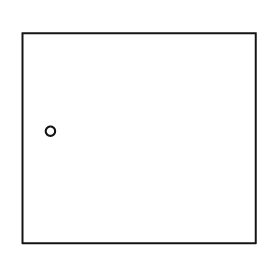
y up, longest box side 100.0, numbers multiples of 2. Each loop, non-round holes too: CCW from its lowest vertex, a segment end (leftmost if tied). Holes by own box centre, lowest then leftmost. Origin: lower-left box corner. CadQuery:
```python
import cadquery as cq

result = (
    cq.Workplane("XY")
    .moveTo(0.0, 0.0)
    .lineTo(100.0, 0.0)
    .lineTo(100.0, 90.0)
    .lineTo(0.0, 90.0)
    .close()
    .moveTo(12.0, 48.0)
    .circle(2.0)
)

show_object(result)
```